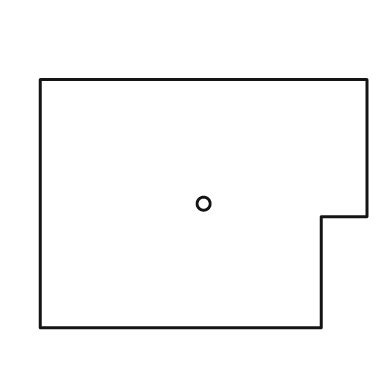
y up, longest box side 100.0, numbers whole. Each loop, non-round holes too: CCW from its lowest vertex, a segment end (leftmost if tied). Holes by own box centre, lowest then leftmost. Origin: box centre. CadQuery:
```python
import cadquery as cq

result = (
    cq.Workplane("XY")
    .moveTo(-50.0, -38.0)
    .lineTo(36.0, -38.0)
    .lineTo(36.0, -4.0)
    .lineTo(50.0, -4.0)
    .lineTo(50.0, 38.0)
    .lineTo(-50.0, 38.0)
    .close()
    .moveTo(0.0, 0.0)
    .circle(2.0)
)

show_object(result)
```